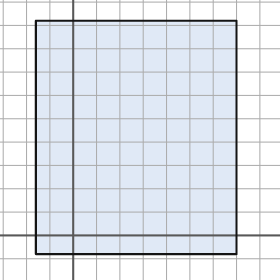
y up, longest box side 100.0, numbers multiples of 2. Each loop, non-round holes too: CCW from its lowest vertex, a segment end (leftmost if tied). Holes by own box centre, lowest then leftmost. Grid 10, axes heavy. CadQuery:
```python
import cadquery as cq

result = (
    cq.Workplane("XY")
    .moveTo(-16.0, -8.0)
    .lineTo(70.0, -8.0)
    .lineTo(70.0, 92.0)
    .lineTo(-16.0, 92.0)
    .close()
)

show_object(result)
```